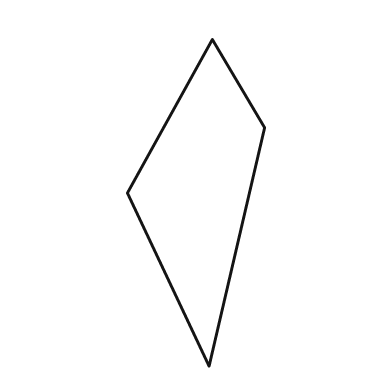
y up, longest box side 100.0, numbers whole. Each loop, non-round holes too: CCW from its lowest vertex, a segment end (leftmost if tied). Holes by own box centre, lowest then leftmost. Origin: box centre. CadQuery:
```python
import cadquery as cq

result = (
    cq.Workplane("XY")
    .moveTo(4.0, -50.0)
    .lineTo(21.0, 23.0)
    .lineTo(5.0, 50.0)
    .lineTo(-21.0, 3.0)
    .close()
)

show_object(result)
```